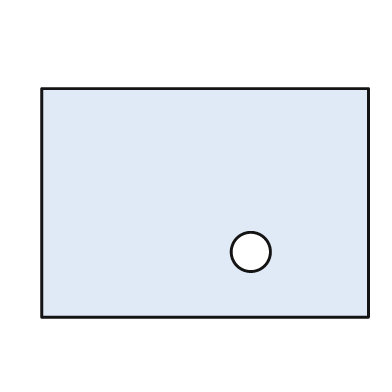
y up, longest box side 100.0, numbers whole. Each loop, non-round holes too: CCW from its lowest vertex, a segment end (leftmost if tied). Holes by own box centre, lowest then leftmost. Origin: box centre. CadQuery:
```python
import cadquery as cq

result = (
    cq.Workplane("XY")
    .moveTo(-50.0, -35.0)
    .lineTo(50.0, -35.0)
    .lineTo(50.0, 35.0)
    .lineTo(-50.0, 35.0)
    .close()
    .moveTo(14.0, -15.0)
    .circle(6.0)
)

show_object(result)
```